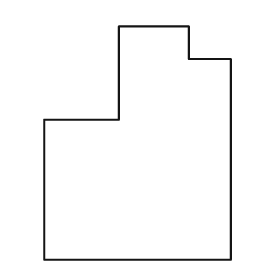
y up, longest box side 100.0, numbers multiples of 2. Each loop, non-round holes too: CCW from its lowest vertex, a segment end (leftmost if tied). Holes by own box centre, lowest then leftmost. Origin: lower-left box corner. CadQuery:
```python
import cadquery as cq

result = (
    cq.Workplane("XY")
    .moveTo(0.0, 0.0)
    .lineTo(80.0, 0.0)
    .lineTo(80.0, 86.0)
    .lineTo(62.0, 86.0)
    .lineTo(62.0, 100.0)
    .lineTo(32.0, 100.0)
    .lineTo(32.0, 60.0)
    .lineTo(0.0, 60.0)
    .close()
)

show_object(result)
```